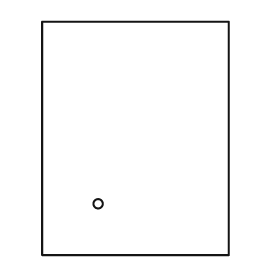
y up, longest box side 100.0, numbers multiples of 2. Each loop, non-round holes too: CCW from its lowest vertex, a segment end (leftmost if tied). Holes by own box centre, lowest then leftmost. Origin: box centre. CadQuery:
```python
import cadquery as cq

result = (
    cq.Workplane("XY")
    .moveTo(-40.0, -50.0)
    .lineTo(40.0, -50.0)
    .lineTo(40.0, 50.0)
    .lineTo(-40.0, 50.0)
    .close()
    .moveTo(-16.0, -28.0)
    .circle(2.0)
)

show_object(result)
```